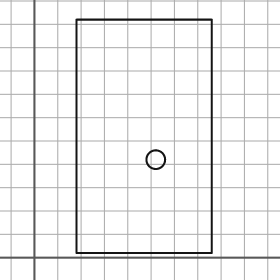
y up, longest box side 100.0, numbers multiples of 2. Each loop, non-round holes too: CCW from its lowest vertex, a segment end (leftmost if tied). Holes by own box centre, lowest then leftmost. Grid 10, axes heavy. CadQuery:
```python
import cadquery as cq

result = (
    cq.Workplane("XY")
    .moveTo(18.0, 2.0)
    .lineTo(76.0, 2.0)
    .lineTo(76.0, 102.0)
    .lineTo(18.0, 102.0)
    .close()
    .moveTo(52.0, 42.0)
    .circle(4.0)
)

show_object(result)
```